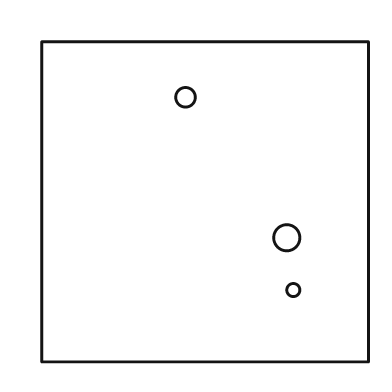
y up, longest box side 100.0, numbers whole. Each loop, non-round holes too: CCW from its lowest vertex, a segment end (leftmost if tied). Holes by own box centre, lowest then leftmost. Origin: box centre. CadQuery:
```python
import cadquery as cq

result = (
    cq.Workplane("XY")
    .moveTo(-50.0, -49.0)
    .lineTo(50.0, -49.0)
    .lineTo(50.0, 49.0)
    .lineTo(-50.0, 49.0)
    .close()
    .moveTo(27.0, -27.0)
    .circle(2.0)
    .moveTo(25.0, -11.0)
    .circle(4.0)
    .moveTo(-6.0, 32.0)
    .circle(3.0)
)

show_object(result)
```